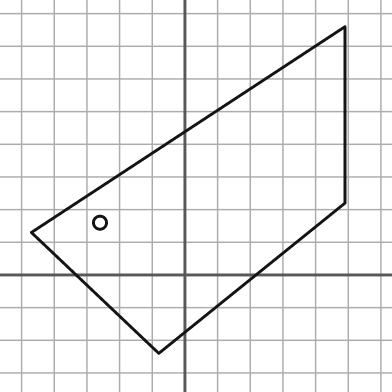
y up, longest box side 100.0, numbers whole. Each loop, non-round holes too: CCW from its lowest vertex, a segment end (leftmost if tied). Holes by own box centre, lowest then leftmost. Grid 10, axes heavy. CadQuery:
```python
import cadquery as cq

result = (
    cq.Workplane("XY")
    .moveTo(-8.0, -24.0)
    .lineTo(49.0, 22.0)
    .lineTo(49.0, 76.0)
    .lineTo(-47.0, 13.0)
    .close()
    .moveTo(-26.0, 16.0)
    .circle(2.0)
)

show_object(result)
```